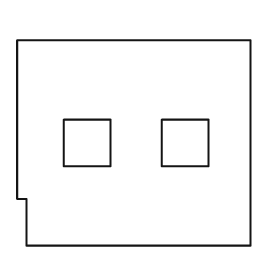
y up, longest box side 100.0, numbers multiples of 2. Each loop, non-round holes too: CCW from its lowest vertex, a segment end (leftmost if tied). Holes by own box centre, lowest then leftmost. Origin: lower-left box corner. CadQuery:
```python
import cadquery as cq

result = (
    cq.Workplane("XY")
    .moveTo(4.0, 0.0)
    .lineTo(100.0, 0.0)
    .lineTo(100.0, 88.0)
    .lineTo(0.0, 88.0)
    .lineTo(0.0, 20.0)
    .lineTo(4.0, 20.0)
    .close()
    .moveTo(20.0, 34.0)
    .lineTo(40.0, 34.0)
    .lineTo(40.0, 54.0)
    .lineTo(20.0, 54.0)
    .close()
    .moveTo(62.0, 34.0)
    .lineTo(82.0, 34.0)
    .lineTo(82.0, 54.0)
    .lineTo(62.0, 54.0)
    .close()
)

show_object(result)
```